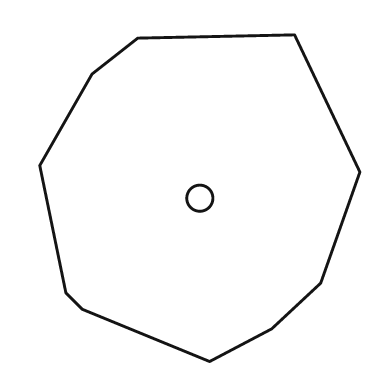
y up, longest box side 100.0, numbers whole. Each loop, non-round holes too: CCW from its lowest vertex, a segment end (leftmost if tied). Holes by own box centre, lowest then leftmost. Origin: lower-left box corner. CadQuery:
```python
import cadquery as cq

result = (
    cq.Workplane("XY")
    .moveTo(52.0, 0.0)
    .lineTo(71.0, 10.0)
    .lineTo(86.0, 24.0)
    .lineTo(98.0, 58.0)
    .lineTo(78.0, 100.0)
    .lineTo(30.0, 99.0)
    .lineTo(16.0, 88.0)
    .lineTo(0.0, 60.0)
    .lineTo(8.0, 21.0)
    .lineTo(13.0, 16.0)
    .close()
    .moveTo(49.0, 50.0)
    .circle(4.0)
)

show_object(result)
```